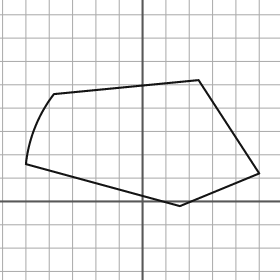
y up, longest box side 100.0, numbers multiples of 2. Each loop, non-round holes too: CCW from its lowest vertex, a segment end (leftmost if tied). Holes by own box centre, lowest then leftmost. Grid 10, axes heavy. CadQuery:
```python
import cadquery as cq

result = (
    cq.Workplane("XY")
    .moveTo(16.0, -2.0)
    .lineTo(50.0, 12.0)
    .lineTo(24.0, 52.0)
    .lineTo(-38.0, 46.0)
    .threePointArc((-46.0, 32.0), (-50.0, 16.0))
    .close()
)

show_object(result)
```